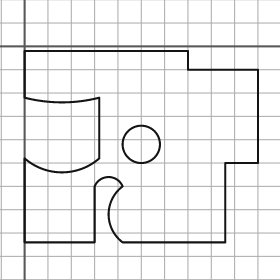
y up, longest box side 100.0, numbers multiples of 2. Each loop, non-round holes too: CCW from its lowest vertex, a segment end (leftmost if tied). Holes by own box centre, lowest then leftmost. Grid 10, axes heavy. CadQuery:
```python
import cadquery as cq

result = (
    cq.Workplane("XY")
    .moveTo(0.0, -84.0)
    .lineTo(30.0, -84.0)
    .lineTo(30.0, -60.0)
    .threePointArc((36.0, -56.0), (42.0, -60.0))
    .threePointArc((36.0, -72.0), (42.0, -84.0))
    .lineTo(86.0, -84.0)
    .lineTo(86.0, -50.0)
    .lineTo(100.0, -50.0)
    .lineTo(100.0, -10.0)
    .lineTo(70.0, -10.0)
    .lineTo(70.0, -2.0)
    .lineTo(0.0, -2.0)
    .lineTo(0.0, -22.0)
    .threePointArc((16.0, -24.0), (32.0, -22.0))
    .lineTo(32.0, -48.0)
    .threePointArc((16.0, -54.0), (0.0, -48.0))
    .close()
    .moveTo(50.0, -42.0)
    .circle(8.0)
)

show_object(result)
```